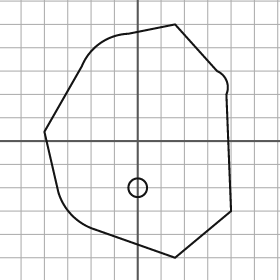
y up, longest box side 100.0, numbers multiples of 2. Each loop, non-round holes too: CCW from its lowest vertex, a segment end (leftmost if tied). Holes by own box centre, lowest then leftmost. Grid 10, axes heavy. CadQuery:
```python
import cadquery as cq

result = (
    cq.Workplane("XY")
    .moveTo(16.0, -50.0)
    .lineTo(40.0, -30.0)
    .lineTo(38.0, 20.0)
    .threePointArc((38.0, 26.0), (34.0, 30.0))
    .lineTo(16.0, 50.0)
    .lineTo(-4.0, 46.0)
    .threePointArc((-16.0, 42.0), (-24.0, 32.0))
    .lineTo(-40.0, 4.0)
    .lineTo(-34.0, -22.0)
    .threePointArc((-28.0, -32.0), (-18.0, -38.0))
    .close()
    .moveTo(0.0, -20.0)
    .circle(4.0)
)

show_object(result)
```